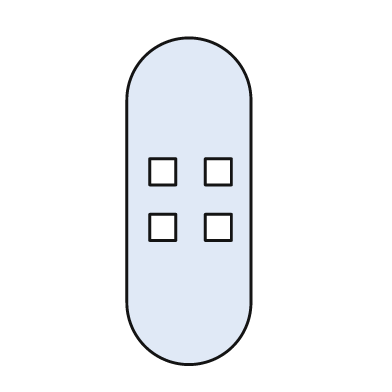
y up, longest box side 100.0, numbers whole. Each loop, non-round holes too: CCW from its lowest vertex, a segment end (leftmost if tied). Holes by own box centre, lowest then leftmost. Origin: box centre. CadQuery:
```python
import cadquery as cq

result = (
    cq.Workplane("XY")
    .moveTo(-19.0, -31.0)
    .threePointArc((0.0, -50.0), (19.0, -31.0))
    .lineTo(19.0, 31.0)
    .threePointArc((0.0, 50.0), (-19.0, 31.0))
    .close()
    .moveTo(-12.0, -12.0)
    .lineTo(-4.0, -12.0)
    .lineTo(-4.0, -4.0)
    .lineTo(-12.0, -4.0)
    .close()
    .moveTo(5.0, -12.0)
    .lineTo(13.0, -12.0)
    .lineTo(13.0, -4.0)
    .lineTo(5.0, -4.0)
    .close()
    .moveTo(-12.0, 5.0)
    .lineTo(-4.0, 5.0)
    .lineTo(-4.0, 13.0)
    .lineTo(-12.0, 13.0)
    .close()
    .moveTo(5.0, 5.0)
    .lineTo(13.0, 5.0)
    .lineTo(13.0, 13.0)
    .lineTo(5.0, 13.0)
    .close()
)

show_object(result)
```